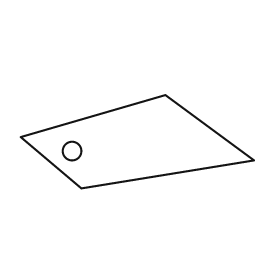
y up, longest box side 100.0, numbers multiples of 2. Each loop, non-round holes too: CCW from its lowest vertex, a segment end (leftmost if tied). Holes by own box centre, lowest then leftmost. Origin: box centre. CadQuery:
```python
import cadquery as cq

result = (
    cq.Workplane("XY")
    .moveTo(-24.0, -20.0)
    .lineTo(50.0, -8.0)
    .lineTo(12.0, 20.0)
    .lineTo(-50.0, 2.0)
    .close()
    .moveTo(-28.0, -4.0)
    .circle(4.0)
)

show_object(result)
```